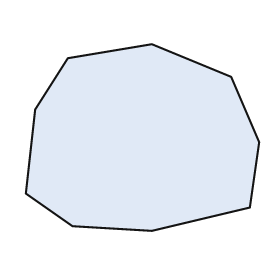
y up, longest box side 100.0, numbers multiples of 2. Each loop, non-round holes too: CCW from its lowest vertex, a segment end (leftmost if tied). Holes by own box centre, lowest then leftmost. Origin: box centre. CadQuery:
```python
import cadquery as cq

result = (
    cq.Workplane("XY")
    .moveTo(4.0, -40.0)
    .lineTo(46.0, -30.0)
    .lineTo(50.0, -2.0)
    .lineTo(38.0, 26.0)
    .lineTo(4.0, 40.0)
    .lineTo(-32.0, 34.0)
    .lineTo(-46.0, 12.0)
    .lineTo(-50.0, -24.0)
    .lineTo(-30.0, -38.0)
    .close()
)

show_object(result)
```